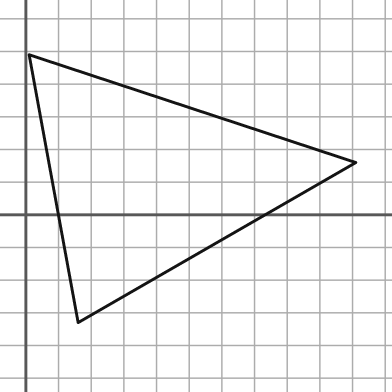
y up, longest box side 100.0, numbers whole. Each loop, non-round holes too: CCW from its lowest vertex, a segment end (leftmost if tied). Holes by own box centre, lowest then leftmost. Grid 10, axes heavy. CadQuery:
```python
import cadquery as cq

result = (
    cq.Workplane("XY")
    .moveTo(16.0, -33.0)
    .lineTo(101.0, 16.0)
    .lineTo(1.0, 49.0)
    .close()
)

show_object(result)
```